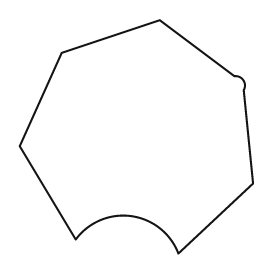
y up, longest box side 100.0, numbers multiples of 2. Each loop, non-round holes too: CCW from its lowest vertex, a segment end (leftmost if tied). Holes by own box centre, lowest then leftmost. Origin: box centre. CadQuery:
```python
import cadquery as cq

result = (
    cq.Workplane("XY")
    .moveTo(18.0, -50.0)
    .lineTo(50.0, -20.0)
    .lineTo(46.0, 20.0)
    .threePointArc((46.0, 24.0), (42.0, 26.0))
    .lineTo(10.0, 50.0)
    .lineTo(-32.0, 36.0)
    .lineTo(-50.0, -4.0)
    .lineTo(-26.0, -44.0)
    .threePointArc((-2.0, -34.0), (18.0, -50.0))
    .close()
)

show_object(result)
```